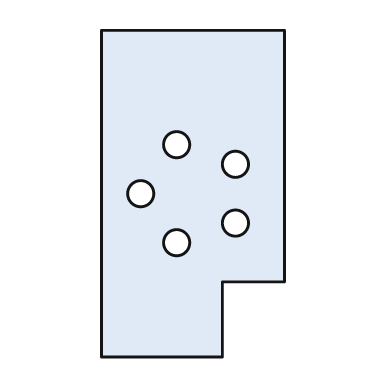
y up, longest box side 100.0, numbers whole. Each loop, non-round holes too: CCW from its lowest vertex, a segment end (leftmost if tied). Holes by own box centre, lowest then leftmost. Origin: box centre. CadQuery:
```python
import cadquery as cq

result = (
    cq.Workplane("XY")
    .moveTo(-28.0, -50.0)
    .lineTo(9.0, -50.0)
    .lineTo(9.0, -27.0)
    .lineTo(28.0, -27.0)
    .lineTo(28.0, 50.0)
    .lineTo(-28.0, 50.0)
    .close()
    .moveTo(-5.0, -15.0)
    .circle(4.0)
    .moveTo(13.0, -9.0)
    .circle(4.0)
    .moveTo(-16.0, 0.0)
    .circle(4.0)
    .moveTo(13.0, 9.0)
    .circle(4.0)
    .moveTo(-5.0, 15.0)
    .circle(4.0)
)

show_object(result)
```